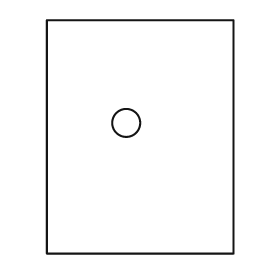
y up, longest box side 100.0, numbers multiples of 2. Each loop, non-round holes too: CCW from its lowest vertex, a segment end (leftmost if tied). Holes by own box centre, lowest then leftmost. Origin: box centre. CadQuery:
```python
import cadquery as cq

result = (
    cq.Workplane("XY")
    .moveTo(-40.0, -50.0)
    .lineTo(40.0, -50.0)
    .lineTo(40.0, 50.0)
    .lineTo(-40.0, 50.0)
    .close()
    .moveTo(-6.0, 6.0)
    .circle(6.0)
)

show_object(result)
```